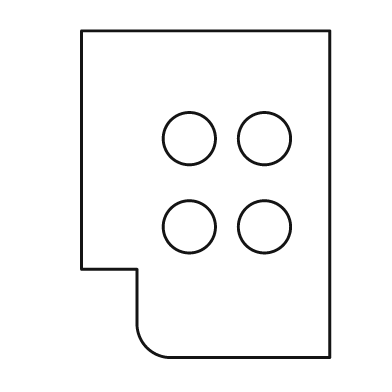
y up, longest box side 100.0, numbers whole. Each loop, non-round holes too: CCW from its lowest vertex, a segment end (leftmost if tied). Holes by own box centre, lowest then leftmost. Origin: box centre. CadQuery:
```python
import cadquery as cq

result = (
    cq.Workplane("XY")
    .moveTo(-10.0, -50.0)
    .lineTo(38.0, -50.0)
    .lineTo(38.0, 50.0)
    .lineTo(-38.0, 50.0)
    .lineTo(-38.0, -23.0)
    .lineTo(-21.0, -23.0)
    .lineTo(-21.0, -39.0)
    .threePointArc((-18.0, -47.0), (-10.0, -50.0))
    .close()
    .moveTo(-5.0, -10.0)
    .circle(8.0)
    .moveTo(18.0, -10.0)
    .circle(8.0)
    .moveTo(-5.0, 17.0)
    .circle(8.0)
    .moveTo(18.0, 17.0)
    .circle(8.0)
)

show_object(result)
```